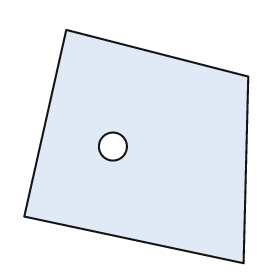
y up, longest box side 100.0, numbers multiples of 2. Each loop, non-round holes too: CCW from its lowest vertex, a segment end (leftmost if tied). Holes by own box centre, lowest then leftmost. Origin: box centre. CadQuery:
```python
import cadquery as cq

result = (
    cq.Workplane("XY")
    .moveTo(46.0, -50.0)
    .lineTo(48.0, 30.0)
    .lineTo(-30.0, 50.0)
    .lineTo(-48.0, -30.0)
    .close()
    .moveTo(-10.0, 0.0)
    .circle(6.0)
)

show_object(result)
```